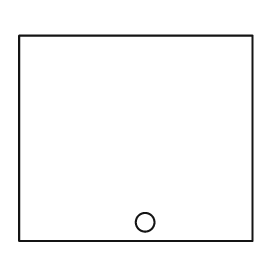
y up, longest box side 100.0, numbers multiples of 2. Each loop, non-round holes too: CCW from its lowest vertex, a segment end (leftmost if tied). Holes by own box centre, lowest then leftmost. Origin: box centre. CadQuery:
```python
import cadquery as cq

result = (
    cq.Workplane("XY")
    .moveTo(-50.0, -44.0)
    .lineTo(50.0, -44.0)
    .lineTo(50.0, 44.0)
    .lineTo(-50.0, 44.0)
    .close()
    .moveTo(4.0, -36.0)
    .circle(4.0)
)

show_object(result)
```